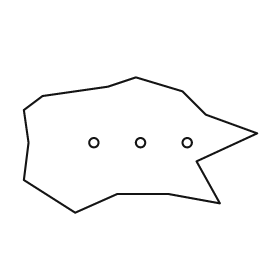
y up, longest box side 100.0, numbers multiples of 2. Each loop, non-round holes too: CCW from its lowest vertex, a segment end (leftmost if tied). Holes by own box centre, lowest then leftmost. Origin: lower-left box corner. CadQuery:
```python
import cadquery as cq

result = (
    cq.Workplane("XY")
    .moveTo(22.0, 0.0)
    .lineTo(40.0, 8.0)
    .lineTo(62.0, 8.0)
    .lineTo(84.0, 4.0)
    .lineTo(74.0, 22.0)
    .lineTo(100.0, 34.0)
    .lineTo(78.0, 42.0)
    .lineTo(68.0, 52.0)
    .lineTo(48.0, 58.0)
    .lineTo(36.0, 54.0)
    .lineTo(8.0, 50.0)
    .lineTo(0.0, 44.0)
    .lineTo(2.0, 30.0)
    .lineTo(0.0, 14.0)
    .close()
    .moveTo(30.0, 30.0)
    .circle(2.0)
    .moveTo(50.0, 30.0)
    .circle(2.0)
    .moveTo(70.0, 30.0)
    .circle(2.0)
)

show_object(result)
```